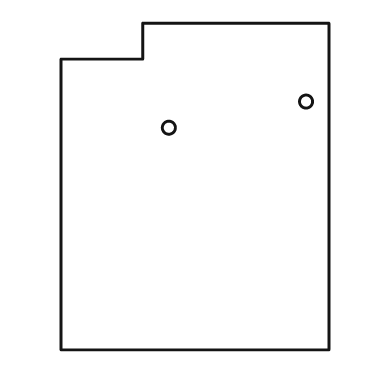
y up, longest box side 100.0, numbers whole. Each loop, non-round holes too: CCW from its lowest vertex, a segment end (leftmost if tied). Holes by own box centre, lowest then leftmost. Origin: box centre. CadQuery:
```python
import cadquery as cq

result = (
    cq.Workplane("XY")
    .moveTo(-41.0, -50.0)
    .lineTo(41.0, -50.0)
    .lineTo(41.0, 50.0)
    .lineTo(-16.0, 50.0)
    .lineTo(-16.0, 39.0)
    .lineTo(-41.0, 39.0)
    .close()
    .moveTo(-8.0, 18.0)
    .circle(2.0)
    .moveTo(34.0, 26.0)
    .circle(2.0)
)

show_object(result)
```